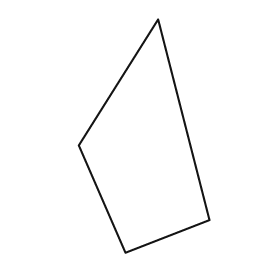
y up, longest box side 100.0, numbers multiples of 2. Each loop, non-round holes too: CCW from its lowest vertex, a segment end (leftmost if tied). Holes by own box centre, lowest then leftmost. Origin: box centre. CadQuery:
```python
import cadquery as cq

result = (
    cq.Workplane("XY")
    .moveTo(-8.0, -50.0)
    .lineTo(28.0, -36.0)
    .lineTo(6.0, 50.0)
    .lineTo(-28.0, -4.0)
    .close()
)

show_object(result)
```